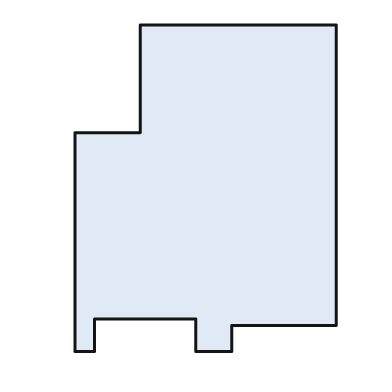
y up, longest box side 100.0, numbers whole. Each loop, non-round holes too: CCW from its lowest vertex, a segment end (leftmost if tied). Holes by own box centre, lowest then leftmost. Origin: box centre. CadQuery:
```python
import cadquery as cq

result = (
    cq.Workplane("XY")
    .moveTo(-40.0, -50.0)
    .lineTo(-34.0, -50.0)
    .lineTo(-34.0, -40.0)
    .lineTo(-3.0, -40.0)
    .lineTo(-3.0, -50.0)
    .lineTo(8.0, -50.0)
    .lineTo(8.0, -42.0)
    .lineTo(40.0, -42.0)
    .lineTo(40.0, 50.0)
    .lineTo(-20.0, 50.0)
    .lineTo(-20.0, 17.0)
    .lineTo(-40.0, 17.0)
    .close()
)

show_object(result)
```